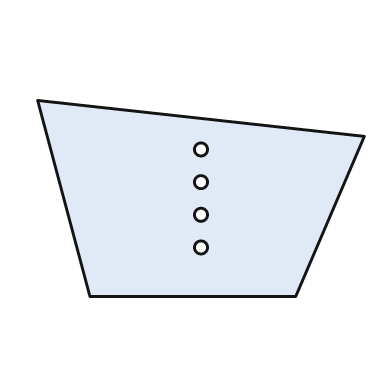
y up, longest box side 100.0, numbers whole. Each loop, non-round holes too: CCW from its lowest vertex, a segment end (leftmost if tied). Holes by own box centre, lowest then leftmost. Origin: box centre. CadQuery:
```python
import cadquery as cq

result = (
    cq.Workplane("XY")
    .moveTo(-34.0, -30.0)
    .lineTo(29.0, -30.0)
    .lineTo(50.0, 19.0)
    .lineTo(-50.0, 30.0)
    .close()
    .moveTo(0.0, -15.0)
    .circle(2.0)
    .moveTo(0.0, -5.0)
    .circle(2.0)
    .moveTo(0.0, 5.0)
    .circle(2.0)
    .moveTo(0.0, 15.0)
    .circle(2.0)
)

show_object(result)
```